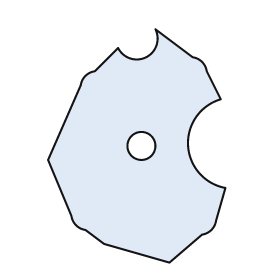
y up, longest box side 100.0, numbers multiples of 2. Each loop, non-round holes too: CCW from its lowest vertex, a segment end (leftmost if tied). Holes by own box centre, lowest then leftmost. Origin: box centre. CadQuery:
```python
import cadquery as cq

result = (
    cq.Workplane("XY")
    .moveTo(14.0, -50.0)
    .lineTo(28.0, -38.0)
    .threePointArc((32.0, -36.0), (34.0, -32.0))
    .lineTo(38.0, -18.0)
    .threePointArc((22.0, 0.0), (36.0, 20.0))
    .lineTo(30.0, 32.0)
    .threePointArc((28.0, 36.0), (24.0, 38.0))
    .lineTo(8.0, 50.0)
    .threePointArc((4.0, 38.0), (-8.0, 42.0))
    .lineTo(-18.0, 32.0)
    .threePointArc((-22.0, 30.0), (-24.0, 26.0))
    .lineTo(-38.0, -6.0)
    .lineTo(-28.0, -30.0)
    .threePointArc((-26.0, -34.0), (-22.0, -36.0))
    .lineTo(-14.0, -42.0)
    .close()
    .moveTo(2.0, 0.0)
    .circle(6.0)
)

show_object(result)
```